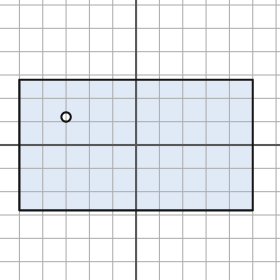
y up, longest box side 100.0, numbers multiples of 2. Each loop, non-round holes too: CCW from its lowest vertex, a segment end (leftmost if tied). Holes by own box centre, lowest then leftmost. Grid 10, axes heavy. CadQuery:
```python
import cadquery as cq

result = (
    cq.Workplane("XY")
    .moveTo(-50.0, -28.0)
    .lineTo(50.0, -28.0)
    .lineTo(50.0, 28.0)
    .lineTo(-50.0, 28.0)
    .close()
    .moveTo(-30.0, 12.0)
    .circle(2.0)
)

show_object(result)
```